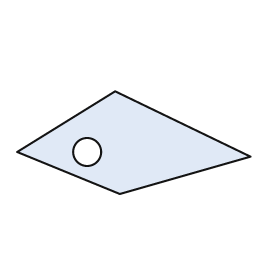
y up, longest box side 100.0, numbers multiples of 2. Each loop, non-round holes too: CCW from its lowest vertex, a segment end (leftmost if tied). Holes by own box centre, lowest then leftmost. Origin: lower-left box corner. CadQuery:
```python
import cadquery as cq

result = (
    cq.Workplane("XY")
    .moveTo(44.0, 0.0)
    .lineTo(100.0, 16.0)
    .lineTo(42.0, 44.0)
    .lineTo(0.0, 18.0)
    .close()
    .moveTo(30.0, 18.0)
    .circle(6.0)
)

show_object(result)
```